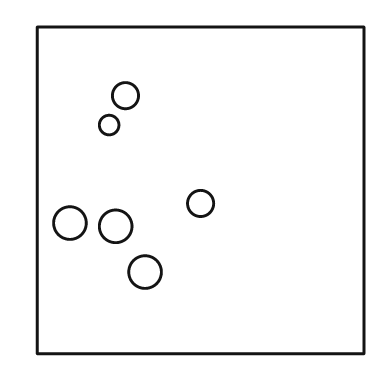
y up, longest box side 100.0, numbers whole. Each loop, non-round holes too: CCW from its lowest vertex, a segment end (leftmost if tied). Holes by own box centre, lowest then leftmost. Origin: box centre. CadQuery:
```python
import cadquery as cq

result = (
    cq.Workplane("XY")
    .moveTo(-50.0, -50.0)
    .lineTo(50.0, -50.0)
    .lineTo(50.0, 50.0)
    .lineTo(-50.0, 50.0)
    .close()
    .moveTo(-17.0, -25.0)
    .circle(5.0)
    .moveTo(-26.0, -11.0)
    .circle(5.0)
    .moveTo(-40.0, -10.0)
    .circle(5.0)
    .moveTo(0.0, -4.0)
    .circle(4.0)
    .moveTo(-28.0, 20.0)
    .circle(3.0)
    .moveTo(-23.0, 29.0)
    .circle(4.0)
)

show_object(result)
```